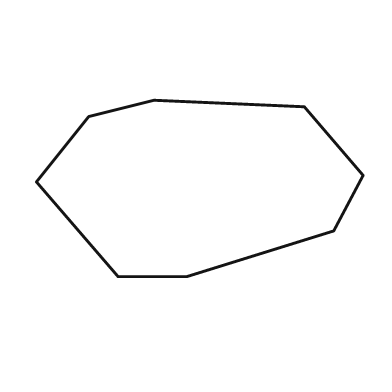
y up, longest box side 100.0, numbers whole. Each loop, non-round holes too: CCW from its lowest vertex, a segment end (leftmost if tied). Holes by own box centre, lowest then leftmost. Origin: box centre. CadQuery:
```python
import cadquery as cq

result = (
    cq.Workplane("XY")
    .moveTo(-25.0, -27.0)
    .lineTo(-4.0, -27.0)
    .lineTo(41.0, -13.0)
    .lineTo(50.0, 4.0)
    .lineTo(32.0, 25.0)
    .lineTo(-14.0, 27.0)
    .lineTo(-34.0, 22.0)
    .lineTo(-50.0, 2.0)
    .close()
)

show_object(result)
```